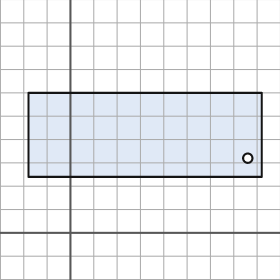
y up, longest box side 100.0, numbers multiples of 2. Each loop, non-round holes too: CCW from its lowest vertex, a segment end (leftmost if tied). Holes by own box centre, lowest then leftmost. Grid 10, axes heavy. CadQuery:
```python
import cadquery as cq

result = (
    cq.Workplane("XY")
    .moveTo(-18.0, 24.0)
    .lineTo(82.0, 24.0)
    .lineTo(82.0, 60.0)
    .lineTo(-18.0, 60.0)
    .close()
    .moveTo(76.0, 32.0)
    .circle(2.0)
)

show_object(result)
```